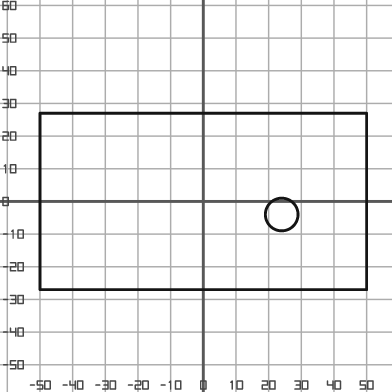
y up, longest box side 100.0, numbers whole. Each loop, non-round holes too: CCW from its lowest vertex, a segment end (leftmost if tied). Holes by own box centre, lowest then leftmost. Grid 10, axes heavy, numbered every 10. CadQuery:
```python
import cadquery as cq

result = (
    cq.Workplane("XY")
    .moveTo(-50.0, -27.0)
    .lineTo(50.0, -27.0)
    .lineTo(50.0, 27.0)
    .lineTo(-50.0, 27.0)
    .close()
    .moveTo(24.0, -4.0)
    .circle(5.0)
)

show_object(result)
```